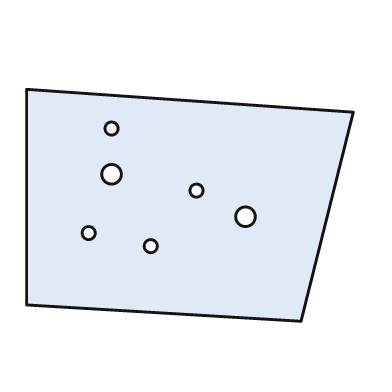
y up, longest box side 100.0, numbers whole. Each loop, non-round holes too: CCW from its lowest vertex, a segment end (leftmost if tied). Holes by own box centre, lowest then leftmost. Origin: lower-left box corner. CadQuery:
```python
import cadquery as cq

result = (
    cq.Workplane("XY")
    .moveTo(84.0, 0.0)
    .lineTo(100.0, 64.0)
    .lineTo(0.0, 71.0)
    .lineTo(0.0, 5.0)
    .close()
    .moveTo(38.0, 23.0)
    .circle(2.0)
    .moveTo(19.0, 27.0)
    .circle(2.0)
    .moveTo(67.0, 32.0)
    .circle(3.0)
    .moveTo(52.0, 40.0)
    .circle(2.0)
    .moveTo(26.0, 45.0)
    .circle(3.0)
    .moveTo(26.0, 59.0)
    .circle(2.0)
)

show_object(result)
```